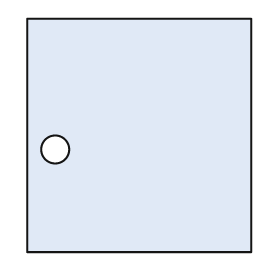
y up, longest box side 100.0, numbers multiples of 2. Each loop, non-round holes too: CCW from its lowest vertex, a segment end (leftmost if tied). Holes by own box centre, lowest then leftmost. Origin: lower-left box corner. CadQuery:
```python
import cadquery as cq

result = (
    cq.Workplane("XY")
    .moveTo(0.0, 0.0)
    .lineTo(96.0, 0.0)
    .lineTo(96.0, 100.0)
    .lineTo(0.0, 100.0)
    .close()
    .moveTo(12.0, 44.0)
    .circle(6.0)
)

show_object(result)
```